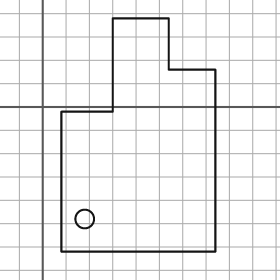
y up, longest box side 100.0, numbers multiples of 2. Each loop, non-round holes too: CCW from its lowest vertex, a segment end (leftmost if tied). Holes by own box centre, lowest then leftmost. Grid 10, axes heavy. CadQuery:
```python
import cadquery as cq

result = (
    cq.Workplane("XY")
    .moveTo(8.0, -62.0)
    .lineTo(74.0, -62.0)
    .lineTo(74.0, 16.0)
    .lineTo(54.0, 16.0)
    .lineTo(54.0, 38.0)
    .lineTo(30.0, 38.0)
    .lineTo(30.0, -2.0)
    .lineTo(8.0, -2.0)
    .close()
    .moveTo(18.0, -48.0)
    .circle(4.0)
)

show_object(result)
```